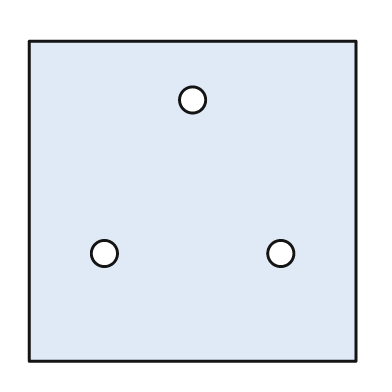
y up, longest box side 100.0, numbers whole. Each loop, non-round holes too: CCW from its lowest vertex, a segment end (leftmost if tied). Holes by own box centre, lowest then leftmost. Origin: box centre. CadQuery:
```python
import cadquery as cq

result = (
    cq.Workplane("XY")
    .moveTo(-50.0, -49.0)
    .lineTo(50.0, -49.0)
    .lineTo(50.0, 49.0)
    .lineTo(-50.0, 49.0)
    .close()
    .moveTo(-27.0, -16.0)
    .circle(4.0)
    .moveTo(27.0, -16.0)
    .circle(4.0)
    .moveTo(0.0, 31.0)
    .circle(4.0)
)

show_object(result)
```